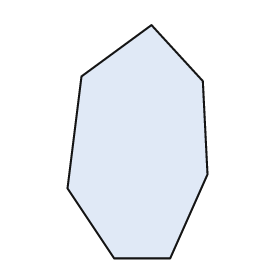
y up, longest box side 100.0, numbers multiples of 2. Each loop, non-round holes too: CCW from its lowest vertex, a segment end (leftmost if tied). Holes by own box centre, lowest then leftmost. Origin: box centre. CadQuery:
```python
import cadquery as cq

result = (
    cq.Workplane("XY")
    .moveTo(-10.0, -50.0)
    .lineTo(14.0, -50.0)
    .lineTo(30.0, -14.0)
    .lineTo(28.0, 26.0)
    .lineTo(6.0, 50.0)
    .lineTo(-24.0, 28.0)
    .lineTo(-30.0, -20.0)
    .close()
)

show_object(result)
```